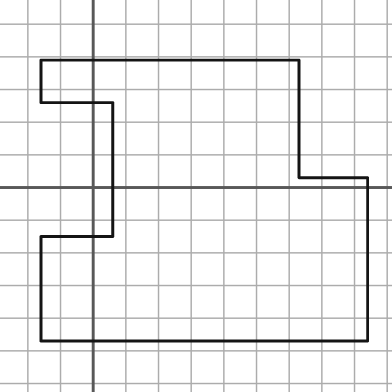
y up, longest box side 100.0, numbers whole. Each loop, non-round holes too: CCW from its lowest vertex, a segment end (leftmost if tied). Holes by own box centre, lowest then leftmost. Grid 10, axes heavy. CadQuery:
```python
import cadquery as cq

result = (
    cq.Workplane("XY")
    .moveTo(-16.0, -47.0)
    .lineTo(84.0, -47.0)
    .lineTo(84.0, 3.0)
    .lineTo(63.0, 3.0)
    .lineTo(63.0, 39.0)
    .lineTo(-16.0, 39.0)
    .lineTo(-16.0, 26.0)
    .lineTo(6.0, 26.0)
    .lineTo(6.0, -15.0)
    .lineTo(-16.0, -15.0)
    .close()
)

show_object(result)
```